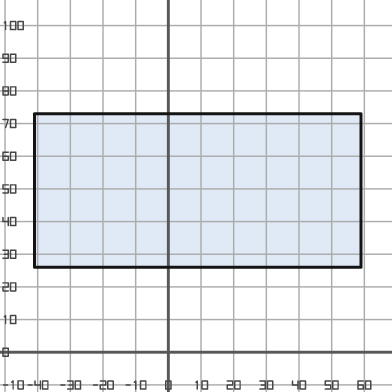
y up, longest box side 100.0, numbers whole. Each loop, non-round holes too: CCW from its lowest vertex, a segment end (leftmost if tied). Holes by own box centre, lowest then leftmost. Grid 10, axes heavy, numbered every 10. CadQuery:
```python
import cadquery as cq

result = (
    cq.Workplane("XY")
    .moveTo(-41.0, 26.0)
    .lineTo(59.0, 26.0)
    .lineTo(59.0, 73.0)
    .lineTo(-41.0, 73.0)
    .close()
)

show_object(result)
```